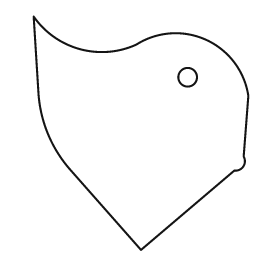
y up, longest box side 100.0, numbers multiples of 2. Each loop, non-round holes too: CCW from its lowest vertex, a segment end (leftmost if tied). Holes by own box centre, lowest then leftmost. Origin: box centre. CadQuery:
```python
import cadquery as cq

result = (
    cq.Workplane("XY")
    .moveTo(0.0, -50.0)
    .lineTo(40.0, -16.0)
    .threePointArc((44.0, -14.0), (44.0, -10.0))
    .lineTo(46.0, 16.0)
    .threePointArc((28.0, 40.0), (-2.0, 38.0))
    .threePointArc((-26.0, 36.0), (-46.0, 50.0))
    .lineTo(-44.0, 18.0)
    .threePointArc((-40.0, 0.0), (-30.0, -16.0))
    .close()
    .moveTo(20.0, 24.0)
    .circle(4.0)
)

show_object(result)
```